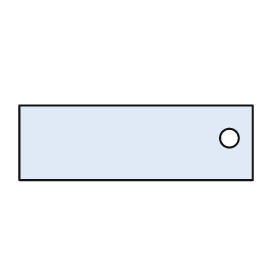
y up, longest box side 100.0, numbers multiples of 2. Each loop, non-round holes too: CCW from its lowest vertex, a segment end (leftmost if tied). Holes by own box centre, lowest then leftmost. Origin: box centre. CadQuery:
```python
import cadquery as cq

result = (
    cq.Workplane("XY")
    .moveTo(-50.0, -16.0)
    .lineTo(50.0, -16.0)
    .lineTo(50.0, 16.0)
    .lineTo(-50.0, 16.0)
    .close()
    .moveTo(40.0, 2.0)
    .circle(4.0)
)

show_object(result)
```